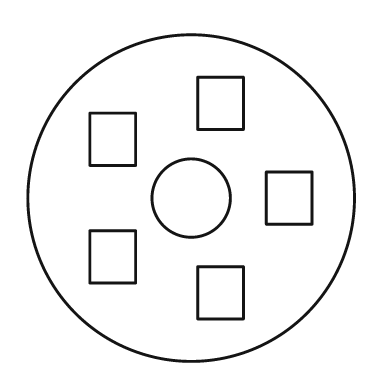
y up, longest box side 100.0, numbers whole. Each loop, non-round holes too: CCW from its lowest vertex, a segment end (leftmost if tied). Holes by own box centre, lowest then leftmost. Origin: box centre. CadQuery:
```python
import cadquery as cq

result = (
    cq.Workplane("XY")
    .moveTo(0.0, 0.0)
    .circle(50.0)
    .moveTo(2.0, -37.0)
    .lineTo(16.0, -37.0)
    .lineTo(16.0, -21.0)
    .lineTo(2.0, -21.0)
    .close()
    .moveTo(-31.0, -26.0)
    .lineTo(-17.0, -26.0)
    .lineTo(-17.0, -10.0)
    .lineTo(-31.0, -10.0)
    .close()
    .moveTo(0.0, 0.0)
    .circle(12.0)
    .moveTo(23.0, -8.0)
    .lineTo(37.0, -8.0)
    .lineTo(37.0, 8.0)
    .lineTo(23.0, 8.0)
    .close()
    .moveTo(-31.0, 10.0)
    .lineTo(-17.0, 10.0)
    .lineTo(-17.0, 26.0)
    .lineTo(-31.0, 26.0)
    .close()
    .moveTo(2.0, 21.0)
    .lineTo(16.0, 21.0)
    .lineTo(16.0, 37.0)
    .lineTo(2.0, 37.0)
    .close()
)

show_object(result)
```